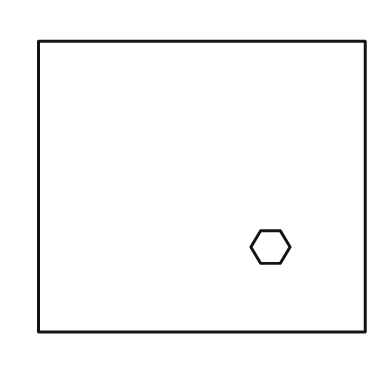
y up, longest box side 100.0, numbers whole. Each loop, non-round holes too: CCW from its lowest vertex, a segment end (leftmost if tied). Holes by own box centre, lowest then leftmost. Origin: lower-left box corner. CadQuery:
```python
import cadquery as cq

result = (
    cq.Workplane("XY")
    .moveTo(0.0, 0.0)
    .lineTo(100.0, 0.0)
    .lineTo(100.0, 89.0)
    .lineTo(0.0, 89.0)
    .close()
    .moveTo(68.0, 21.0)
    .lineTo(74.0, 21.0)
    .lineTo(77.0, 26.0)
    .lineTo(74.0, 31.0)
    .lineTo(68.0, 31.0)
    .lineTo(65.0, 26.0)
    .close()
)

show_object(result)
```